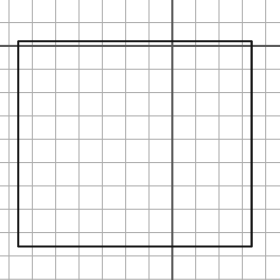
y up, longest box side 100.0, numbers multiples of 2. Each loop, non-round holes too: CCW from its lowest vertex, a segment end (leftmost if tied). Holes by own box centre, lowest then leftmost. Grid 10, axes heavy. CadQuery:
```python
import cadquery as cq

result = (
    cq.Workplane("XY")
    .moveTo(-66.0, -86.0)
    .lineTo(34.0, -86.0)
    .lineTo(34.0, 2.0)
    .lineTo(-66.0, 2.0)
    .close()
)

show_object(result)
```